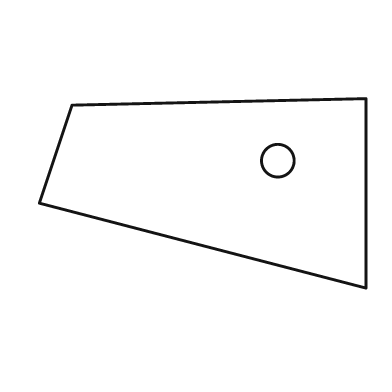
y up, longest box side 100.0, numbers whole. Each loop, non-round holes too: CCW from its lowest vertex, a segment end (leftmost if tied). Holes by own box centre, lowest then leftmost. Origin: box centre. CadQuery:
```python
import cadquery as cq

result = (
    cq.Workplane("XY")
    .moveTo(50.0, -29.0)
    .lineTo(50.0, 29.0)
    .lineTo(-40.0, 27.0)
    .lineTo(-50.0, -3.0)
    .close()
    .moveTo(23.0, 10.0)
    .circle(5.0)
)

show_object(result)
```